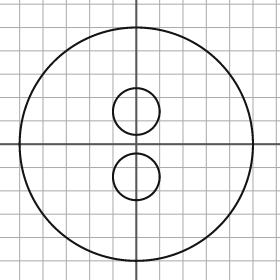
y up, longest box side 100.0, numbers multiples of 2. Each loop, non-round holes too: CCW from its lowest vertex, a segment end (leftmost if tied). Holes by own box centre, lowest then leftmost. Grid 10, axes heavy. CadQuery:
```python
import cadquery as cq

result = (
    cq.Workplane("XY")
    .moveTo(0.0, 0.0)
    .circle(50.0)
    .moveTo(0.0, -14.0)
    .circle(10.0)
    .moveTo(0.0, 14.0)
    .circle(10.0)
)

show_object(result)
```